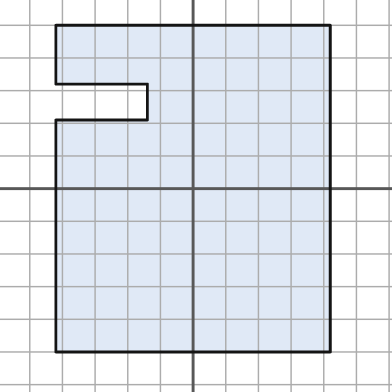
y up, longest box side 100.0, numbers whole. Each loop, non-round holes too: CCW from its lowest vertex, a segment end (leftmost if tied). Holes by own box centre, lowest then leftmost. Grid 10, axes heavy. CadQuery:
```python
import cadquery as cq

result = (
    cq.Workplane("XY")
    .moveTo(-42.0, -50.0)
    .lineTo(42.0, -50.0)
    .lineTo(42.0, 50.0)
    .lineTo(-42.0, 50.0)
    .lineTo(-42.0, 32.0)
    .lineTo(-14.0, 32.0)
    .lineTo(-14.0, 21.0)
    .lineTo(-42.0, 21.0)
    .close()
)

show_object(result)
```